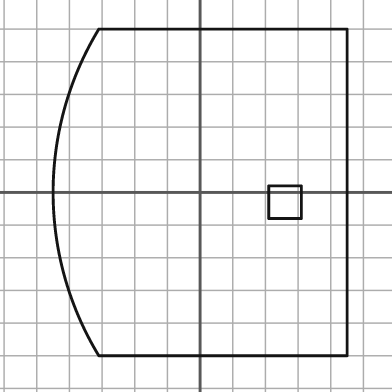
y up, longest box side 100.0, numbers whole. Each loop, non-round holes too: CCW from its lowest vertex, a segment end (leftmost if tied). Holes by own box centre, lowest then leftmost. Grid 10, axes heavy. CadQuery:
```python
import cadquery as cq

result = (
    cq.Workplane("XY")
    .moveTo(-31.0, -50.0)
    .lineTo(45.0, -50.0)
    .lineTo(45.0, 50.0)
    .lineTo(-31.0, 50.0)
    .threePointArc((-45.0, 0.0), (-31.0, -50.0))
    .close()
    .moveTo(21.0, -8.0)
    .lineTo(31.0, -8.0)
    .lineTo(31.0, 2.0)
    .lineTo(21.0, 2.0)
    .close()
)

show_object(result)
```